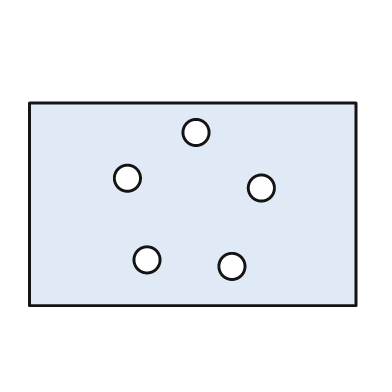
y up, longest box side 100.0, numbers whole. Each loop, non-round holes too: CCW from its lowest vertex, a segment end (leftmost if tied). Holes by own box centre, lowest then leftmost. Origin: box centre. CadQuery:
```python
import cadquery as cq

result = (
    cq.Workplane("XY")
    .moveTo(-50.0, -31.0)
    .lineTo(50.0, -31.0)
    .lineTo(50.0, 31.0)
    .lineTo(-50.0, 31.0)
    .close()
    .moveTo(12.0, -19.0)
    .circle(4.0)
    .moveTo(-14.0, -17.0)
    .circle(4.0)
    .moveTo(21.0, 5.0)
    .circle(4.0)
    .moveTo(-20.0, 8.0)
    .circle(4.0)
    .moveTo(1.0, 22.0)
    .circle(4.0)
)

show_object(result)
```